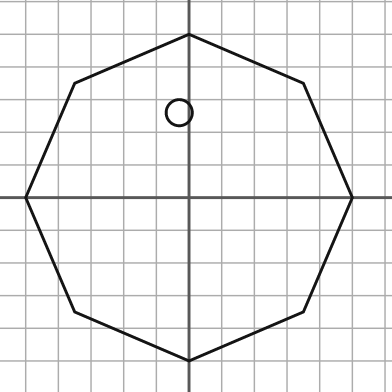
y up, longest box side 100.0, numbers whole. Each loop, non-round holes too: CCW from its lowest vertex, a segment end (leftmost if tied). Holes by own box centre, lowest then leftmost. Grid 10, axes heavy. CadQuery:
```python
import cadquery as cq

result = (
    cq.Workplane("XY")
    .moveTo(0.0, -50.0)
    .lineTo(35.0, -35.0)
    .lineTo(50.0, 0.0)
    .lineTo(35.0, 35.0)
    .lineTo(0.0, 50.0)
    .lineTo(-35.0, 35.0)
    .lineTo(-50.0, 0.0)
    .lineTo(-35.0, -35.0)
    .close()
    .moveTo(-3.0, 26.0)
    .circle(4.0)
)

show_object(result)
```